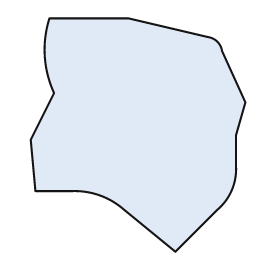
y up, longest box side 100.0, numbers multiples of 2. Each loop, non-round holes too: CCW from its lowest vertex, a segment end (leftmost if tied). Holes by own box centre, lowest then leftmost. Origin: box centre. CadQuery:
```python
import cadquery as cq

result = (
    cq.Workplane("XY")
    .moveTo(16.0, -50.0)
    .lineTo(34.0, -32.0)
    .threePointArc((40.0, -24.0), (42.0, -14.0))
    .lineTo(42.0, 0.0)
    .lineTo(46.0, 14.0)
    .lineTo(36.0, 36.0)
    .threePointArc((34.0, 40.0), (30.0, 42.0))
    .lineTo(-4.0, 50.0)
    .lineTo(-38.0, 50.0)
    .threePointArc((-40.0, 34.0), (-36.0, 18.0))
    .lineTo(-46.0, -2.0)
    .lineTo(-44.0, -24.0)
    .lineTo(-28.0, -24.0)
    .threePointArc((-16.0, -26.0), (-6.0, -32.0))
    .close()
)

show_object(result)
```